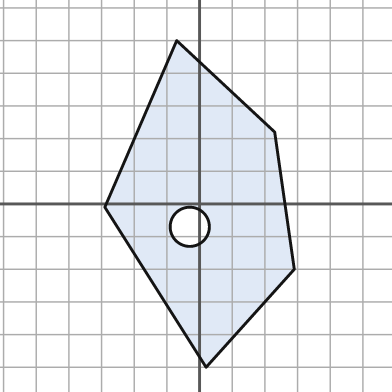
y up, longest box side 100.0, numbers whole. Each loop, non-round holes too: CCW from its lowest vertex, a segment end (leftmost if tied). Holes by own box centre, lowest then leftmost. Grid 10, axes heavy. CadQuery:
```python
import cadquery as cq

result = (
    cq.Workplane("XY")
    .moveTo(2.0, -50.0)
    .lineTo(29.0, -20.0)
    .lineTo(23.0, 22.0)
    .lineTo(-7.0, 50.0)
    .lineTo(-29.0, -1.0)
    .close()
    .moveTo(-3.0, -7.0)
    .circle(6.0)
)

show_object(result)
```